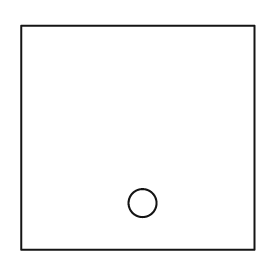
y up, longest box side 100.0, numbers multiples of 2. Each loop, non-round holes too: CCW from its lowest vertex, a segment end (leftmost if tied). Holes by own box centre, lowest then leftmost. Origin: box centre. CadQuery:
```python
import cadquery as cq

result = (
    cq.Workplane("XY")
    .moveTo(-50.0, -48.0)
    .lineTo(50.0, -48.0)
    .lineTo(50.0, 48.0)
    .lineTo(-50.0, 48.0)
    .close()
    .moveTo(2.0, -28.0)
    .circle(6.0)
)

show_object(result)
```